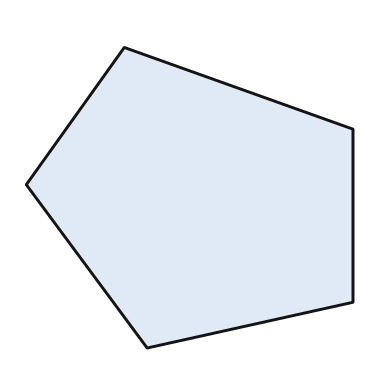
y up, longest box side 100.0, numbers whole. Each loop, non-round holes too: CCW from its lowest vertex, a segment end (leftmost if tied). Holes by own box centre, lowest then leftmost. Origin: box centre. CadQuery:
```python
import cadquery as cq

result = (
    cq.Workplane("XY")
    .moveTo(-13.0, -46.0)
    .lineTo(50.0, -32.0)
    .lineTo(50.0, 21.0)
    .lineTo(-20.0, 46.0)
    .lineTo(-50.0, 4.0)
    .close()
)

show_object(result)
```